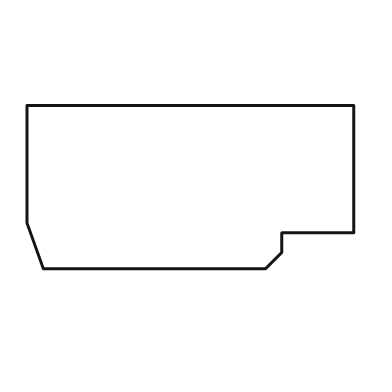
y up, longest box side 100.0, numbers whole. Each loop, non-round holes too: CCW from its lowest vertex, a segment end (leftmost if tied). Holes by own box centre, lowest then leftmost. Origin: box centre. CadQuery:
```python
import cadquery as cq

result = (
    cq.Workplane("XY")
    .moveTo(-45.0, -25.0)
    .lineTo(23.0, -25.0)
    .lineTo(28.0, -20.0)
    .lineTo(28.0, -14.0)
    .lineTo(50.0, -14.0)
    .lineTo(50.0, 25.0)
    .lineTo(-50.0, 25.0)
    .lineTo(-50.0, -11.0)
    .close()
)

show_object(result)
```